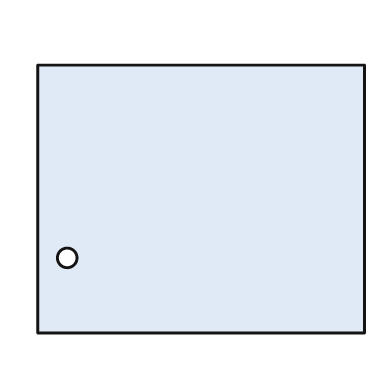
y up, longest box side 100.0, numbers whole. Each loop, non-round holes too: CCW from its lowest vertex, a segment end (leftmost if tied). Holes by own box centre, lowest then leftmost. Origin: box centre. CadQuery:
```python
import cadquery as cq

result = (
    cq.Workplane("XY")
    .moveTo(-50.0, -41.0)
    .lineTo(50.0, -41.0)
    .lineTo(50.0, 41.0)
    .lineTo(-50.0, 41.0)
    .close()
    .moveTo(-41.0, -18.0)
    .circle(3.0)
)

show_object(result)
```